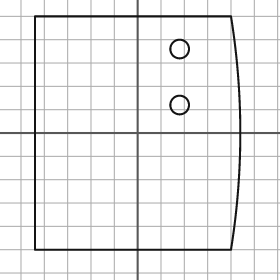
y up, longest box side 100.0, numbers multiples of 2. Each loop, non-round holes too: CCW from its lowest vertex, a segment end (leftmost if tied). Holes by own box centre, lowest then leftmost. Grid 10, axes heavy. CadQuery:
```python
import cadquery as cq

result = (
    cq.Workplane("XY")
    .moveTo(-44.0, -50.0)
    .lineTo(40.0, -50.0)
    .threePointArc((44.0, 0.0), (40.0, 50.0))
    .lineTo(-44.0, 50.0)
    .close()
    .moveTo(18.0, 12.0)
    .circle(4.0)
    .moveTo(18.0, 36.0)
    .circle(4.0)
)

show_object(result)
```